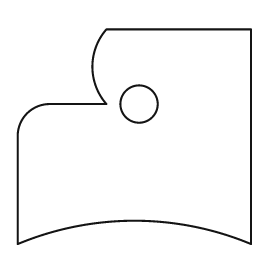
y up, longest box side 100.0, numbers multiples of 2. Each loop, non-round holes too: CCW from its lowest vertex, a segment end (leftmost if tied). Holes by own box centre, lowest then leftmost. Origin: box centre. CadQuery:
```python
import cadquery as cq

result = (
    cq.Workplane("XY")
    .moveTo(-50.0, -46.0)
    .threePointArc((0.0, -36.0), (50.0, -46.0))
    .lineTo(50.0, 46.0)
    .lineTo(-12.0, 46.0)
    .threePointArc((-18.0, 30.0), (-12.0, 14.0))
    .lineTo(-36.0, 14.0)
    .threePointArc((-46.0, 10.0), (-50.0, 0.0))
    .close()
    .moveTo(2.0, 14.0)
    .circle(8.0)
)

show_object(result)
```